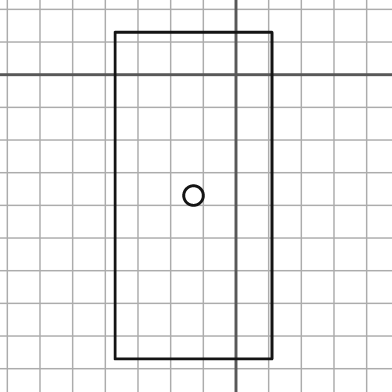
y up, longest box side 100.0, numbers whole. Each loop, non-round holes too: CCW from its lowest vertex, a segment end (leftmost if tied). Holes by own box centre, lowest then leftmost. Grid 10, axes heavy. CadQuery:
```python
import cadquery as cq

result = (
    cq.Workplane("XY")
    .moveTo(-37.0, -87.0)
    .lineTo(11.0, -87.0)
    .lineTo(11.0, 13.0)
    .lineTo(-37.0, 13.0)
    .close()
    .moveTo(-13.0, -37.0)
    .circle(3.0)
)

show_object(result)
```